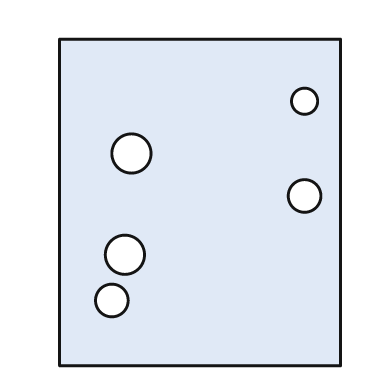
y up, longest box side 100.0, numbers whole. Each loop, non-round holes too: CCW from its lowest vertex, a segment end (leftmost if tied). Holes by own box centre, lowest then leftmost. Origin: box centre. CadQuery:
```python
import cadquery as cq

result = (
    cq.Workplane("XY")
    .moveTo(-43.0, -50.0)
    .lineTo(43.0, -50.0)
    .lineTo(43.0, 50.0)
    .lineTo(-43.0, 50.0)
    .close()
    .moveTo(-27.0, -30.0)
    .circle(5.0)
    .moveTo(-23.0, -16.0)
    .circle(6.0)
    .moveTo(32.0, 2.0)
    .circle(5.0)
    .moveTo(-21.0, 15.0)
    .circle(6.0)
    .moveTo(32.0, 31.0)
    .circle(4.0)
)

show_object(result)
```